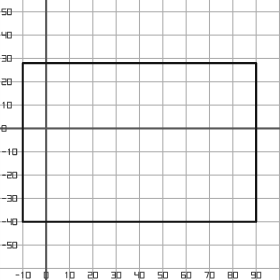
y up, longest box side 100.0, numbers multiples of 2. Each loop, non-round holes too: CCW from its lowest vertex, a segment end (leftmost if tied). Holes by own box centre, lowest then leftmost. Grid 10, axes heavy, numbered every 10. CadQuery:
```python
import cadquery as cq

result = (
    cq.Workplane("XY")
    .moveTo(-10.0, -40.0)
    .lineTo(90.0, -40.0)
    .lineTo(90.0, 28.0)
    .lineTo(-10.0, 28.0)
    .close()
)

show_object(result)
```